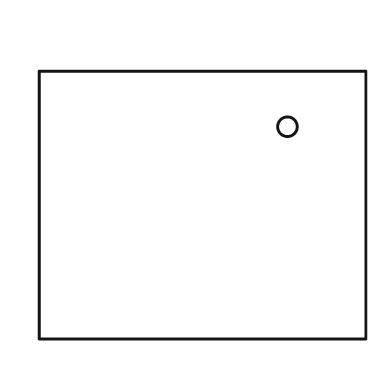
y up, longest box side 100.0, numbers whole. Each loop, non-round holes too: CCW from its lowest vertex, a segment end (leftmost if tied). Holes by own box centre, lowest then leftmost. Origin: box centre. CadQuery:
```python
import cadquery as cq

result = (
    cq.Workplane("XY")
    .moveTo(-50.0, -41.0)
    .lineTo(50.0, -41.0)
    .lineTo(50.0, 41.0)
    .lineTo(-50.0, 41.0)
    .close()
    .moveTo(26.0, 24.0)
    .circle(3.0)
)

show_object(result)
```